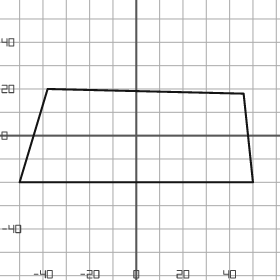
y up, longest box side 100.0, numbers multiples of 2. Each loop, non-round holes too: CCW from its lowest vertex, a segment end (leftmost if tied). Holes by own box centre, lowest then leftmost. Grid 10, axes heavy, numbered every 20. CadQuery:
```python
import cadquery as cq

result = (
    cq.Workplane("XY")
    .moveTo(-50.0, -20.0)
    .lineTo(50.0, -20.0)
    .lineTo(46.0, 18.0)
    .lineTo(-38.0, 20.0)
    .close()
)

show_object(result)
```